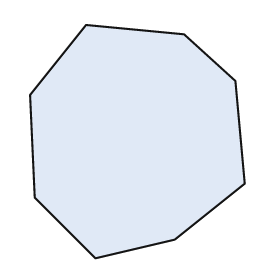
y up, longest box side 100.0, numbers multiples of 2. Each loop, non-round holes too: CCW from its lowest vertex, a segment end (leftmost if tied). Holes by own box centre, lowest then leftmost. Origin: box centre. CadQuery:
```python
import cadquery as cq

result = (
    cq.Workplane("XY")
    .moveTo(-18.0, -50.0)
    .lineTo(16.0, -42.0)
    .lineTo(46.0, -18.0)
    .lineTo(42.0, 26.0)
    .lineTo(20.0, 46.0)
    .lineTo(-22.0, 50.0)
    .lineTo(-46.0, 20.0)
    .lineTo(-44.0, -24.0)
    .close()
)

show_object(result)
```